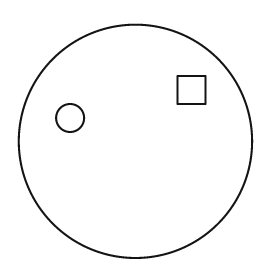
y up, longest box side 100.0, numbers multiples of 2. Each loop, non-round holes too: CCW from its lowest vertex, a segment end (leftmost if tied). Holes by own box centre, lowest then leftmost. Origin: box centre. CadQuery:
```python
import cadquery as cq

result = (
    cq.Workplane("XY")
    .moveTo(0.0, 0.0)
    .circle(50.0)
    .moveTo(-28.0, 10.0)
    .circle(6.0)
    .moveTo(18.0, 16.0)
    .lineTo(30.0, 16.0)
    .lineTo(30.0, 28.0)
    .lineTo(18.0, 28.0)
    .close()
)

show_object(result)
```